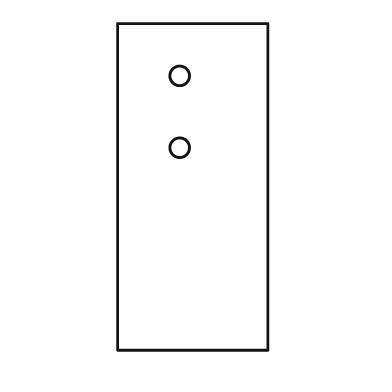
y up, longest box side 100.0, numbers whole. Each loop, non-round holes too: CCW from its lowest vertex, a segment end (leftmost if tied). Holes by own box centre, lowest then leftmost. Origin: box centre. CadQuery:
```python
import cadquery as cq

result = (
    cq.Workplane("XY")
    .moveTo(-23.0, -50.0)
    .lineTo(23.0, -50.0)
    .lineTo(23.0, 50.0)
    .lineTo(-23.0, 50.0)
    .close()
    .moveTo(-4.0, 12.0)
    .circle(3.0)
    .moveTo(-4.0, 34.0)
    .circle(3.0)
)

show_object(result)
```